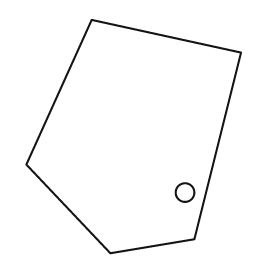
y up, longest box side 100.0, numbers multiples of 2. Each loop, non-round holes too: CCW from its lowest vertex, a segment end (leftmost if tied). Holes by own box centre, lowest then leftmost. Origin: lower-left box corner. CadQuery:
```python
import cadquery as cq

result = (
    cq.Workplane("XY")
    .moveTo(36.0, 0.0)
    .lineTo(72.0, 6.0)
    .lineTo(92.0, 86.0)
    .lineTo(28.0, 100.0)
    .lineTo(0.0, 38.0)
    .close()
    .moveTo(68.0, 26.0)
    .circle(4.0)
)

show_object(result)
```